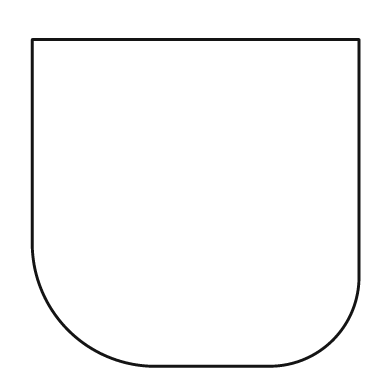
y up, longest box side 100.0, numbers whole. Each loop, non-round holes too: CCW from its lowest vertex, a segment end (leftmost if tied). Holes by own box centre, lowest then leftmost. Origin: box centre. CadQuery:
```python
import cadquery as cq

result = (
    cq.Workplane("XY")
    .moveTo(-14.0, -50.0)
    .lineTo(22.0, -50.0)
    .threePointArc((42.0, -42.0), (50.0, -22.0))
    .lineTo(50.0, 50.0)
    .lineTo(-50.0, 50.0)
    .lineTo(-50.0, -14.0)
    .threePointArc((-39.0, -39.0), (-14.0, -50.0))
    .close()
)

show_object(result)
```